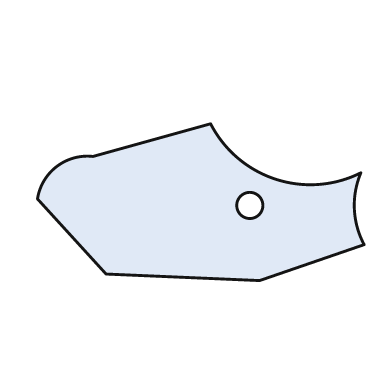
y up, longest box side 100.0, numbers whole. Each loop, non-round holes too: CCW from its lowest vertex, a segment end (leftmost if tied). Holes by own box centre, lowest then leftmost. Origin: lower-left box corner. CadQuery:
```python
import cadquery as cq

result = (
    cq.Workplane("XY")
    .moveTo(68.0, 0.0)
    .lineTo(100.0, 11.0)
    .threePointArc((97.0, 22.0), (99.0, 33.0))
    .threePointArc((73.0, 31.0), (53.0, 48.0))
    .lineTo(17.0, 38.0)
    .threePointArc((6.0, 35.0), (0.0, 25.0))
    .lineTo(21.0, 2.0)
    .close()
    .moveTo(65.0, 23.0)
    .circle(4.0)
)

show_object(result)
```